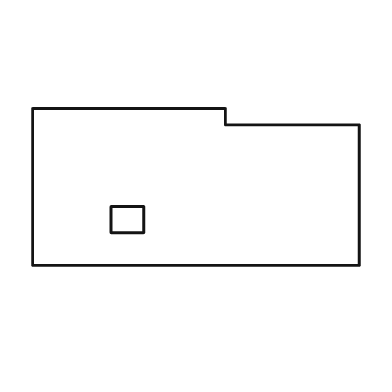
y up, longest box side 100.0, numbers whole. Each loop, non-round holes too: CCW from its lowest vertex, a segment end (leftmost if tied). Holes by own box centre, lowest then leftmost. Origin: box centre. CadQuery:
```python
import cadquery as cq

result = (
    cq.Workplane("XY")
    .moveTo(-50.0, -24.0)
    .lineTo(50.0, -24.0)
    .lineTo(50.0, 19.0)
    .lineTo(9.0, 19.0)
    .lineTo(9.0, 24.0)
    .lineTo(-50.0, 24.0)
    .close()
    .moveTo(-26.0, -14.0)
    .lineTo(-16.0, -14.0)
    .lineTo(-16.0, -6.0)
    .lineTo(-26.0, -6.0)
    .close()
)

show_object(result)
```